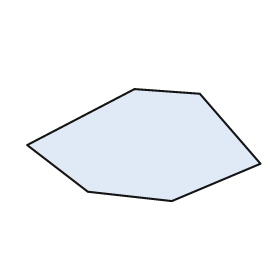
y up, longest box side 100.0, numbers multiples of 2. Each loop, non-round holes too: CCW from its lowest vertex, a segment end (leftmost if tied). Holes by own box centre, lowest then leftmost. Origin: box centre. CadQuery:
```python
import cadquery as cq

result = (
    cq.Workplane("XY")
    .moveTo(12.0, -24.0)
    .lineTo(50.0, -8.0)
    .lineTo(24.0, 22.0)
    .lineTo(-4.0, 24.0)
    .lineTo(-50.0, 0.0)
    .lineTo(-24.0, -20.0)
    .close()
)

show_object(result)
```